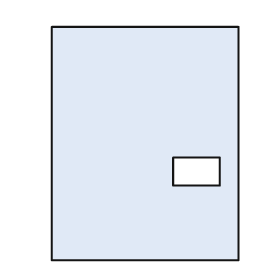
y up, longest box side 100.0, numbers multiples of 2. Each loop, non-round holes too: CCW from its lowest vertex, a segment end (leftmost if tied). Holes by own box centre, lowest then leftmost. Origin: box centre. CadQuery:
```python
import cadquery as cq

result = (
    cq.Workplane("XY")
    .moveTo(-40.0, -50.0)
    .lineTo(40.0, -50.0)
    .lineTo(40.0, 50.0)
    .lineTo(-40.0, 50.0)
    .close()
    .moveTo(12.0, -18.0)
    .lineTo(32.0, -18.0)
    .lineTo(32.0, -6.0)
    .lineTo(12.0, -6.0)
    .close()
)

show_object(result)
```